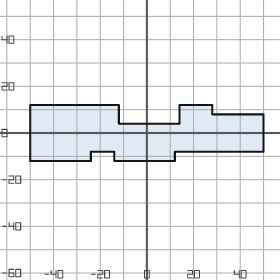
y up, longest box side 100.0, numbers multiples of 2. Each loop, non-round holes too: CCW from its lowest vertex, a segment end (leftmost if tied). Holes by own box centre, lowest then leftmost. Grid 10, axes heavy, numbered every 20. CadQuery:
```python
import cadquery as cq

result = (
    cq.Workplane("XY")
    .moveTo(-50.0, -12.0)
    .lineTo(-24.0, -12.0)
    .lineTo(-24.0, -8.0)
    .lineTo(-14.0, -8.0)
    .lineTo(-14.0, -12.0)
    .lineTo(12.0, -12.0)
    .lineTo(12.0, -8.0)
    .lineTo(50.0, -8.0)
    .lineTo(50.0, 8.0)
    .lineTo(28.0, 8.0)
    .lineTo(28.0, 12.0)
    .lineTo(14.0, 12.0)
    .lineTo(14.0, 4.0)
    .lineTo(-12.0, 4.0)
    .lineTo(-12.0, 12.0)
    .lineTo(-50.0, 12.0)
    .close()
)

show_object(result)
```